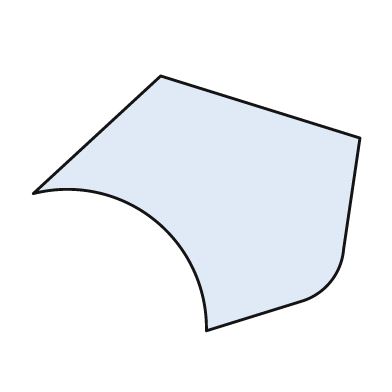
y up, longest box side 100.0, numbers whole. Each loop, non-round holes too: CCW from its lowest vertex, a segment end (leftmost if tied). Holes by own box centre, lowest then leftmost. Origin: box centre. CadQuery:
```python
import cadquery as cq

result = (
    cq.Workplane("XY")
    .moveTo(3.0, -39.0)
    .lineTo(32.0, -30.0)
    .threePointArc((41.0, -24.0), (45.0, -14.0))
    .lineTo(50.0, 20.0)
    .lineTo(-11.0, 39.0)
    .lineTo(-50.0, 3.0)
    .threePointArc((-13.0, -5.0), (3.0, -39.0))
    .close()
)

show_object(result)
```